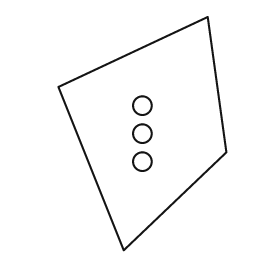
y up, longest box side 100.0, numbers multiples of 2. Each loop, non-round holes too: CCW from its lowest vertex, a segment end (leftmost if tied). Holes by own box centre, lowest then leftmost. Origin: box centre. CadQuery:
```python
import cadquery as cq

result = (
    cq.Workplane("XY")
    .moveTo(-8.0, -50.0)
    .lineTo(36.0, -8.0)
    .lineTo(28.0, 50.0)
    .lineTo(-36.0, 20.0)
    .close()
    .moveTo(0.0, -12.0)
    .circle(4.0)
    .moveTo(0.0, 0.0)
    .circle(4.0)
    .moveTo(0.0, 12.0)
    .circle(4.0)
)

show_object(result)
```